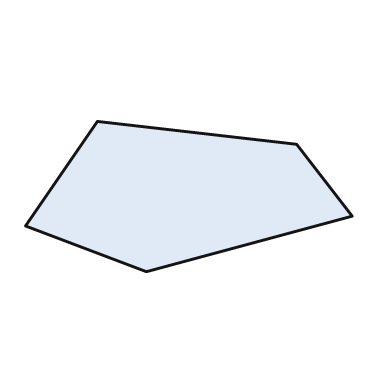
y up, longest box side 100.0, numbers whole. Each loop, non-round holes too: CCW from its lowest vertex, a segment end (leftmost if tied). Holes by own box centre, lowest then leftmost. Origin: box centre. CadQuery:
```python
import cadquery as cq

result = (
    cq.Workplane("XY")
    .moveTo(-13.0, -23.0)
    .lineTo(50.0, -6.0)
    .lineTo(33.0, 16.0)
    .lineTo(-28.0, 23.0)
    .lineTo(-50.0, -9.0)
    .close()
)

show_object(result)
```